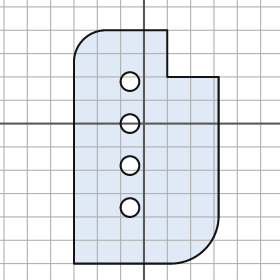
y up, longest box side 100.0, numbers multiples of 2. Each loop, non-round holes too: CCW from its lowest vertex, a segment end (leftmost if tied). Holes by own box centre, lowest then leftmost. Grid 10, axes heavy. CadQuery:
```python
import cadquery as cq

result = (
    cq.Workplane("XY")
    .moveTo(-30.0, -60.0)
    .lineTo(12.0, -60.0)
    .threePointArc((26.0, -54.0), (32.0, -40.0))
    .lineTo(32.0, 20.0)
    .lineTo(10.0, 20.0)
    .lineTo(10.0, 40.0)
    .lineTo(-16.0, 40.0)
    .threePointArc((-26.0, 36.0), (-30.0, 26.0))
    .close()
    .moveTo(-6.0, -36.0)
    .circle(4.0)
    .moveTo(-6.0, -18.0)
    .circle(4.0)
    .moveTo(-6.0, 0.0)
    .circle(4.0)
    .moveTo(-6.0, 18.0)
    .circle(4.0)
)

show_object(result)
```